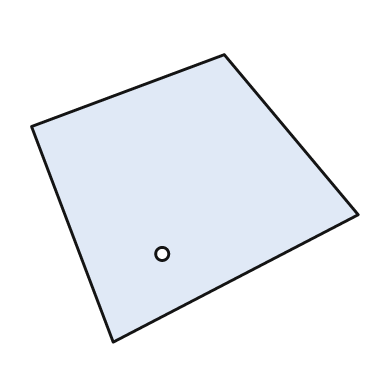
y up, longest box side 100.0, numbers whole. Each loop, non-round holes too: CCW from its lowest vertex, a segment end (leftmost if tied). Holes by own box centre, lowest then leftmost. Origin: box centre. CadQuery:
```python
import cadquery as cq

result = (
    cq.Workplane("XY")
    .moveTo(-25.0, -44.0)
    .lineTo(50.0, -5.0)
    .lineTo(9.0, 44.0)
    .lineTo(-50.0, 22.0)
    .close()
    .moveTo(-10.0, -17.0)
    .circle(2.0)
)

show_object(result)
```